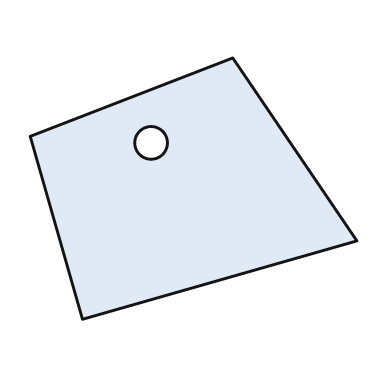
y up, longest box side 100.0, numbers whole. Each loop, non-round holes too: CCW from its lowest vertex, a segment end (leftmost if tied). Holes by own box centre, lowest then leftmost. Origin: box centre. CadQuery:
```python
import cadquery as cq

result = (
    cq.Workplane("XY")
    .moveTo(-34.0, -40.0)
    .lineTo(50.0, -16.0)
    .lineTo(12.0, 40.0)
    .lineTo(-50.0, 16.0)
    .close()
    .moveTo(-13.0, 14.0)
    .circle(5.0)
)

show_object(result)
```